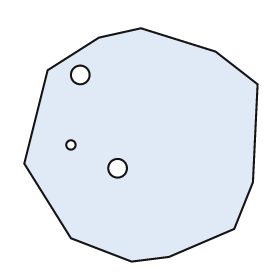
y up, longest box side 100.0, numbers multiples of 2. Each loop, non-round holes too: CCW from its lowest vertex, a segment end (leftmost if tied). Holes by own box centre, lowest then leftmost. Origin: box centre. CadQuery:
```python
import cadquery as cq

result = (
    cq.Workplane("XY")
    .moveTo(-4.0, -50.0)
    .lineTo(12.0, -48.0)
    .lineTo(40.0, -36.0)
    .lineTo(48.0, -16.0)
    .lineTo(50.0, 26.0)
    .lineTo(32.0, 40.0)
    .lineTo(0.0, 50.0)
    .lineTo(-18.0, 46.0)
    .lineTo(-40.0, 32.0)
    .lineTo(-50.0, -8.0)
    .lineTo(-30.0, -40.0)
    .close()
    .moveTo(-10.0, -10.0)
    .circle(4.0)
    .moveTo(-30.0, 0.0)
    .circle(2.0)
    .moveTo(-26.0, 30.0)
    .circle(4.0)
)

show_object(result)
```